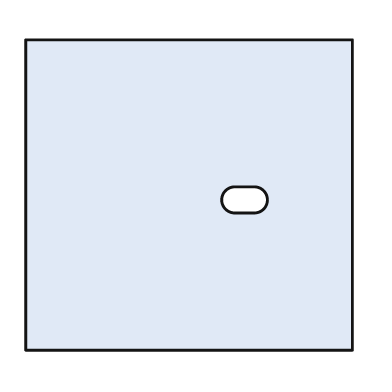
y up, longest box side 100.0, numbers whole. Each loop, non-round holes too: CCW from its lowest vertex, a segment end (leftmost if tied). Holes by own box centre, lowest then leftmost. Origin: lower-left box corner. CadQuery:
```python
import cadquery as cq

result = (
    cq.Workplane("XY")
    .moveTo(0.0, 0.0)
    .lineTo(100.0, 0.0)
    .lineTo(100.0, 95.0)
    .lineTo(0.0, 95.0)
    .close()
    .moveTo(64.0, 42.0)
    .lineTo(70.0, 42.0)
    .threePointArc((74.0, 46.0), (70.0, 50.0))
    .lineTo(64.0, 50.0)
    .threePointArc((60.0, 46.0), (64.0, 42.0))
    .close()
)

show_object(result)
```